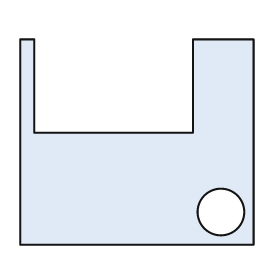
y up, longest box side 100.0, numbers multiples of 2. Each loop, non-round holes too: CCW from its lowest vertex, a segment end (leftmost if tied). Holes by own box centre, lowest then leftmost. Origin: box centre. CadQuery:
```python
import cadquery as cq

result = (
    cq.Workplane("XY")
    .moveTo(-50.0, -44.0)
    .lineTo(50.0, -44.0)
    .lineTo(50.0, 44.0)
    .lineTo(24.0, 44.0)
    .lineTo(24.0, 4.0)
    .lineTo(-44.0, 4.0)
    .lineTo(-44.0, 44.0)
    .lineTo(-50.0, 44.0)
    .close()
    .moveTo(36.0, -30.0)
    .circle(10.0)
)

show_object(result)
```